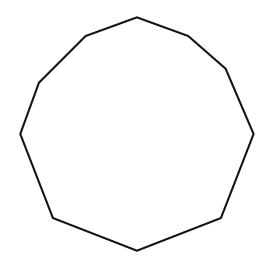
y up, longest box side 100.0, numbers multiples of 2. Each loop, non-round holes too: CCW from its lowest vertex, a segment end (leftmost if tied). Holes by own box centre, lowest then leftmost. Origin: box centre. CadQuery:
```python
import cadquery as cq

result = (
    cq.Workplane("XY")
    .moveTo(0.0, -50.0)
    .lineTo(36.0, -36.0)
    .lineTo(50.0, 0.0)
    .lineTo(38.0, 28.0)
    .lineTo(22.0, 42.0)
    .lineTo(0.0, 50.0)
    .lineTo(-22.0, 42.0)
    .lineTo(-42.0, 22.0)
    .lineTo(-50.0, 0.0)
    .lineTo(-36.0, -36.0)
    .close()
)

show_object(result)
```